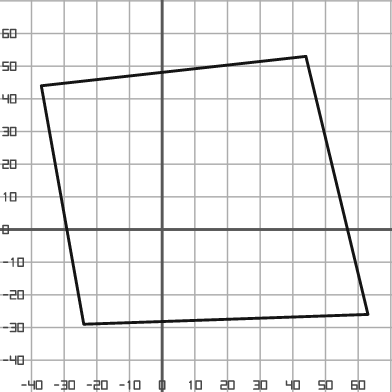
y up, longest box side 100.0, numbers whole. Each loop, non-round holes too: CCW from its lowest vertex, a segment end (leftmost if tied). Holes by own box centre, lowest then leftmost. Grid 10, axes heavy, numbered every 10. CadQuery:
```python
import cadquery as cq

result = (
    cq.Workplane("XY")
    .moveTo(-24.0, -29.0)
    .lineTo(63.0, -26.0)
    .lineTo(44.0, 53.0)
    .lineTo(-37.0, 44.0)
    .close()
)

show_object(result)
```